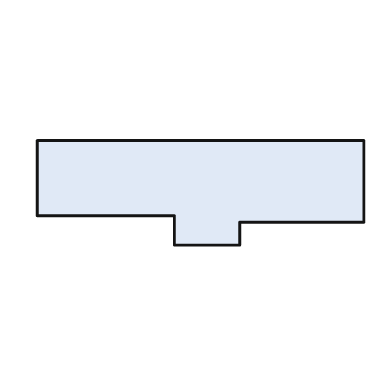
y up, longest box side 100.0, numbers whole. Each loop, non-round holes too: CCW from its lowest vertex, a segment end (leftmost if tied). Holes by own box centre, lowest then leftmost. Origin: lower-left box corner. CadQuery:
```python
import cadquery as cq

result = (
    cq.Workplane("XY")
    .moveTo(42.0, 0.0)
    .lineTo(62.0, 0.0)
    .lineTo(62.0, 7.0)
    .lineTo(100.0, 7.0)
    .lineTo(100.0, 32.0)
    .lineTo(0.0, 32.0)
    .lineTo(0.0, 9.0)
    .lineTo(42.0, 9.0)
    .close()
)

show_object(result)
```